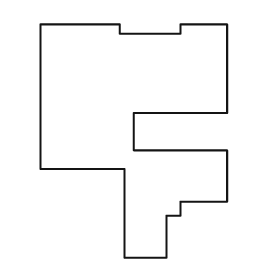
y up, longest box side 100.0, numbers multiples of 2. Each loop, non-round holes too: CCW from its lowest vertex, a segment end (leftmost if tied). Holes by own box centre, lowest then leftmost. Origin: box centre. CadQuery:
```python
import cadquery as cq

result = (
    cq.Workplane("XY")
    .moveTo(-4.0, -50.0)
    .lineTo(14.0, -50.0)
    .lineTo(14.0, -32.0)
    .lineTo(20.0, -32.0)
    .lineTo(20.0, -26.0)
    .lineTo(40.0, -26.0)
    .lineTo(40.0, -4.0)
    .lineTo(0.0, -4.0)
    .lineTo(0.0, 12.0)
    .lineTo(40.0, 12.0)
    .lineTo(40.0, 50.0)
    .lineTo(20.0, 50.0)
    .lineTo(20.0, 46.0)
    .lineTo(-6.0, 46.0)
    .lineTo(-6.0, 50.0)
    .lineTo(-40.0, 50.0)
    .lineTo(-40.0, -12.0)
    .lineTo(-4.0, -12.0)
    .close()
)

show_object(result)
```